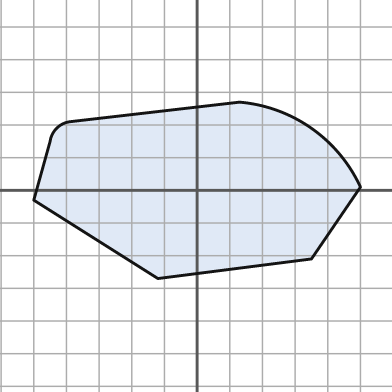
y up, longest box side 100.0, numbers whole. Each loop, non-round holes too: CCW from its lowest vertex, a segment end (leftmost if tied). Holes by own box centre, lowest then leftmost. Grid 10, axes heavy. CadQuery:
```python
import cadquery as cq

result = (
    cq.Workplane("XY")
    .moveTo(-12.0, -27.0)
    .lineTo(35.0, -21.0)
    .lineTo(50.0, 1.0)
    .threePointArc((35.0, 19.0), (13.0, 27.0))
    .lineTo(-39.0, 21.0)
    .threePointArc((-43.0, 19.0), (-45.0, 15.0))
    .lineTo(-50.0, -3.0)
    .close()
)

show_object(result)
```